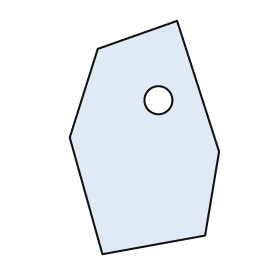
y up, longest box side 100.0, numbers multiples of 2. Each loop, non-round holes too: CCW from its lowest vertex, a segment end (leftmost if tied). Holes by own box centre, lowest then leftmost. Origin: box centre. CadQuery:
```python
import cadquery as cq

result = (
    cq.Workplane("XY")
    .moveTo(-18.0, -50.0)
    .lineTo(26.0, -42.0)
    .lineTo(32.0, -6.0)
    .lineTo(14.0, 50.0)
    .lineTo(-20.0, 38.0)
    .lineTo(-32.0, 0.0)
    .close()
    .moveTo(6.0, 16.0)
    .circle(6.0)
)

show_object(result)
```